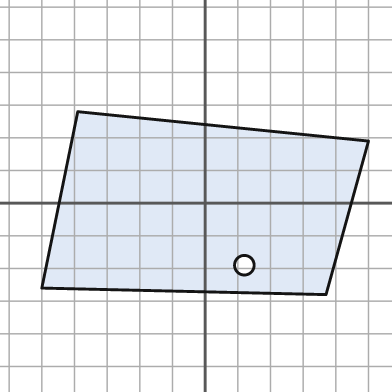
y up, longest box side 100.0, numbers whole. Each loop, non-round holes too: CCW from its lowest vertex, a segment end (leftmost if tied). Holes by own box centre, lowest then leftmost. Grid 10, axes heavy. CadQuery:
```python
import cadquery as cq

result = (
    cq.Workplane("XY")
    .moveTo(37.0, -28.0)
    .lineTo(50.0, 19.0)
    .lineTo(-39.0, 28.0)
    .lineTo(-50.0, -26.0)
    .close()
    .moveTo(12.0, -19.0)
    .circle(3.0)
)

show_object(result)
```